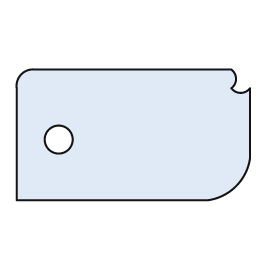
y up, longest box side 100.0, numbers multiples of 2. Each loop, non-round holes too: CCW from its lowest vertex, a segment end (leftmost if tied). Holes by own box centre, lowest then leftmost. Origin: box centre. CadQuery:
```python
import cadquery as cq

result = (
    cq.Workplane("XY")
    .moveTo(-50.0, -28.0)
    .lineTo(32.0, -28.0)
    .threePointArc((44.0, -22.0), (50.0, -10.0))
    .lineTo(50.0, 20.0)
    .threePointArc((46.0, 18.0), (42.0, 20.0))
    .threePointArc((44.0, 24.0), (42.0, 28.0))
    .lineTo(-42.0, 28.0)
    .threePointArc((-48.0, 26.0), (-50.0, 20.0))
    .close()
    .moveTo(-32.0, -2.0)
    .circle(6.0)
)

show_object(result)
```